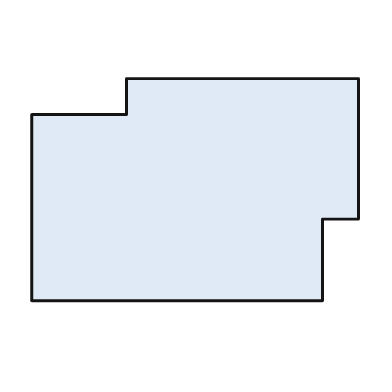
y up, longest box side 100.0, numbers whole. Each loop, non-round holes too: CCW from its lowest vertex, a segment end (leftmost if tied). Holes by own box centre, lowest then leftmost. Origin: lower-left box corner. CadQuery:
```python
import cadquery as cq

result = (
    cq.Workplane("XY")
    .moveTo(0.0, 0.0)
    .lineTo(89.0, 0.0)
    .lineTo(89.0, 25.0)
    .lineTo(100.0, 25.0)
    .lineTo(100.0, 68.0)
    .lineTo(29.0, 68.0)
    .lineTo(29.0, 57.0)
    .lineTo(0.0, 57.0)
    .close()
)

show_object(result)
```